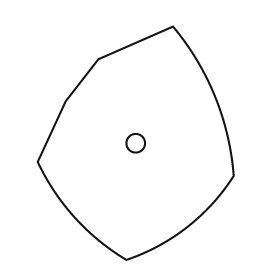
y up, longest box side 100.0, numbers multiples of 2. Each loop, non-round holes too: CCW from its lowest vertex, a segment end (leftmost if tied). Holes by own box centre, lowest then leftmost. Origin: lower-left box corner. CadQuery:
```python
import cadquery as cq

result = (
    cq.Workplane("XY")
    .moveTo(38.0, 0.0)
    .threePointArc((64.0, 14.0), (84.0, 36.0))
    .threePointArc((76.0, 70.0), (58.0, 100.0))
    .lineTo(26.0, 86.0)
    .lineTo(12.0, 68.0)
    .lineTo(0.0, 42.0)
    .threePointArc((16.0, 18.0), (38.0, 0.0))
    .close()
    .moveTo(42.0, 50.0)
    .circle(4.0)
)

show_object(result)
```